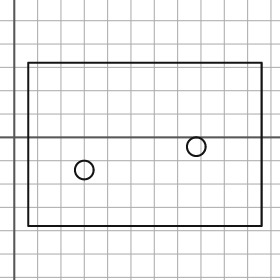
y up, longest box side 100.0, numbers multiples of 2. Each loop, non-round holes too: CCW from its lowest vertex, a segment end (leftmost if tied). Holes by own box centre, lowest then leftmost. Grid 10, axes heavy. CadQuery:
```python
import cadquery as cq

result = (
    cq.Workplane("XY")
    .moveTo(6.0, -38.0)
    .lineTo(106.0, -38.0)
    .lineTo(106.0, 32.0)
    .lineTo(6.0, 32.0)
    .close()
    .moveTo(30.0, -14.0)
    .circle(4.0)
    .moveTo(78.0, -4.0)
    .circle(4.0)
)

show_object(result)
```